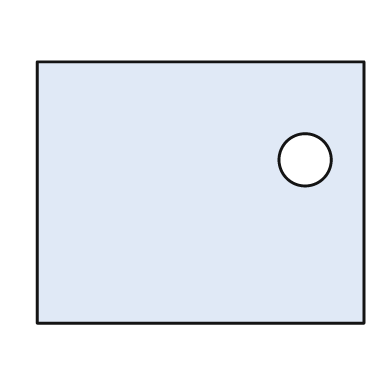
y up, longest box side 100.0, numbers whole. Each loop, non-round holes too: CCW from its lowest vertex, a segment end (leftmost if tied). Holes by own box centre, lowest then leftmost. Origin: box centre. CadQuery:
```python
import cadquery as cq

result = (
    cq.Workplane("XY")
    .moveTo(-50.0, -40.0)
    .lineTo(50.0, -40.0)
    .lineTo(50.0, 40.0)
    .lineTo(-50.0, 40.0)
    .close()
    .moveTo(32.0, 10.0)
    .circle(8.0)
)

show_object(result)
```